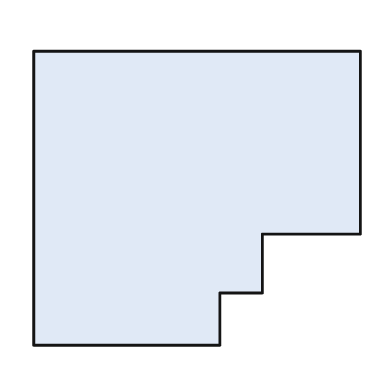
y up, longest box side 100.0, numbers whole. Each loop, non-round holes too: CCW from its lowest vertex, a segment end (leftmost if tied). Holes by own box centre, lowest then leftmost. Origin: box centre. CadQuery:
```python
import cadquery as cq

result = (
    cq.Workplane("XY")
    .moveTo(-50.0, -45.0)
    .lineTo(7.0, -45.0)
    .lineTo(7.0, -29.0)
    .lineTo(20.0, -29.0)
    .lineTo(20.0, -11.0)
    .lineTo(50.0, -11.0)
    .lineTo(50.0, 45.0)
    .lineTo(-50.0, 45.0)
    .close()
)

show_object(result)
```